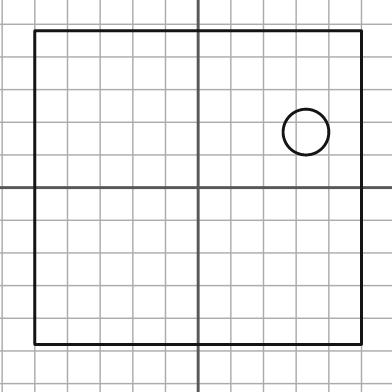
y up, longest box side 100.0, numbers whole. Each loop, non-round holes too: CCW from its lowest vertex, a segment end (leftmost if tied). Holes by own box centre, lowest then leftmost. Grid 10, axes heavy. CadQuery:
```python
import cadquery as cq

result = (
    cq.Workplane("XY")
    .moveTo(-50.0, -48.0)
    .lineTo(50.0, -48.0)
    .lineTo(50.0, 48.0)
    .lineTo(-50.0, 48.0)
    .close()
    .moveTo(33.0, 17.0)
    .circle(7.0)
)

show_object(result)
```